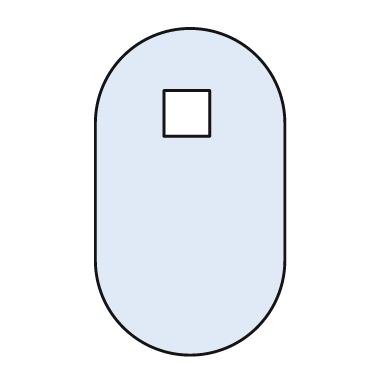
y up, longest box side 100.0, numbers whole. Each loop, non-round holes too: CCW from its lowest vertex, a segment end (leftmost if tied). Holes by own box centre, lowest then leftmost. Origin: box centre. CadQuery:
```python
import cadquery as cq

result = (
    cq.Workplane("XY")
    .moveTo(-29.0, -21.0)
    .threePointArc((0.0, -50.0), (29.0, -21.0))
    .lineTo(29.0, 21.0)
    .threePointArc((0.0, 50.0), (-29.0, 21.0))
    .close()
    .moveTo(-8.0, 17.0)
    .lineTo(6.0, 17.0)
    .lineTo(6.0, 31.0)
    .lineTo(-8.0, 31.0)
    .close()
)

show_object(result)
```